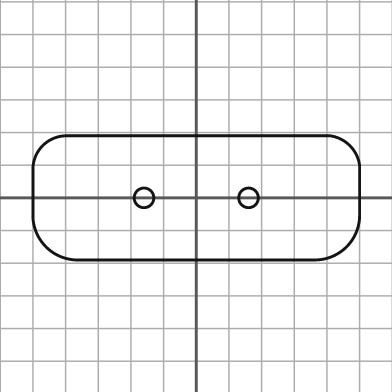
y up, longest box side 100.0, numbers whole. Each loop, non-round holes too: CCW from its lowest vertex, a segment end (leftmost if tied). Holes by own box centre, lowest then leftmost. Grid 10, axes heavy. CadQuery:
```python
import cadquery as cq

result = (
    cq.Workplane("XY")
    .moveTo(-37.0, -19.0)
    .lineTo(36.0, -19.0)
    .threePointArc((46.0, -15.0), (50.0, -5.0))
    .lineTo(50.0, 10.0)
    .threePointArc((47.0, 16.0), (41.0, 19.0))
    .lineTo(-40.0, 19.0)
    .threePointArc((-47.0, 16.0), (-50.0, 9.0))
    .lineTo(-50.0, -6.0)
    .threePointArc((-46.0, -15.0), (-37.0, -19.0))
    .close()
    .moveTo(-16.0, 0.0)
    .circle(3.0)
    .moveTo(16.0, 0.0)
    .circle(3.0)
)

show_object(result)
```